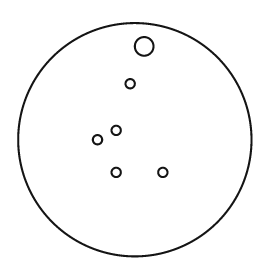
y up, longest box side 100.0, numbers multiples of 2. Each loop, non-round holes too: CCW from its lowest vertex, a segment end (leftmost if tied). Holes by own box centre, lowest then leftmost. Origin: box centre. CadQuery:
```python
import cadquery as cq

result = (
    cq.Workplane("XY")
    .moveTo(0.0, 0.0)
    .circle(50.0)
    .moveTo(-8.0, -14.0)
    .circle(2.0)
    .moveTo(12.0, -14.0)
    .circle(2.0)
    .moveTo(-16.0, 0.0)
    .circle(2.0)
    .moveTo(-8.0, 4.0)
    .circle(2.0)
    .moveTo(-2.0, 24.0)
    .circle(2.0)
    .moveTo(4.0, 40.0)
    .circle(4.0)
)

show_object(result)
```